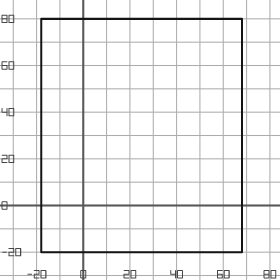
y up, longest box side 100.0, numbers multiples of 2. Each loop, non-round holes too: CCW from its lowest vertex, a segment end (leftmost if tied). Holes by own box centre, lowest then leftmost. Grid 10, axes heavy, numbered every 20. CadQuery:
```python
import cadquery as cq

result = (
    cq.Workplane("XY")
    .moveTo(-18.0, -20.0)
    .lineTo(68.0, -20.0)
    .lineTo(68.0, 80.0)
    .lineTo(-18.0, 80.0)
    .close()
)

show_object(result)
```